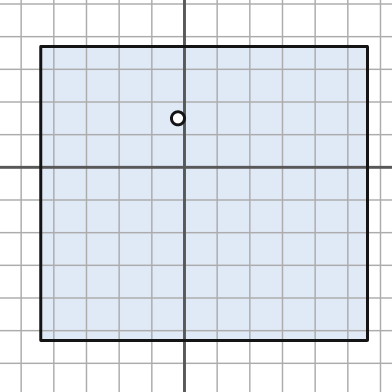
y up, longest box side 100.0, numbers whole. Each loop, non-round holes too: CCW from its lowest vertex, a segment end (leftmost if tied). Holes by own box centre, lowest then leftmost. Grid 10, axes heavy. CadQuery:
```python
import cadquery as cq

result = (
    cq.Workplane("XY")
    .moveTo(-44.0, -53.0)
    .lineTo(56.0, -53.0)
    .lineTo(56.0, 37.0)
    .lineTo(-44.0, 37.0)
    .close()
    .moveTo(-2.0, 15.0)
    .circle(2.0)
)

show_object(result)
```